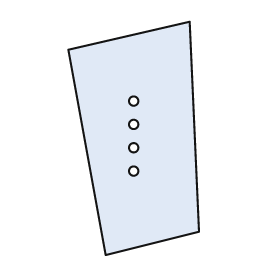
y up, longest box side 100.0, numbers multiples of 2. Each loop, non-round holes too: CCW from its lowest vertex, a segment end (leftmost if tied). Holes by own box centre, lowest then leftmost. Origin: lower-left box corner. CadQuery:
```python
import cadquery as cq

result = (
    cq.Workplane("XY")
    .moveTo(16.0, 0.0)
    .lineTo(56.0, 10.0)
    .lineTo(52.0, 100.0)
    .lineTo(0.0, 88.0)
    .close()
    .moveTo(28.0, 36.0)
    .circle(2.0)
    .moveTo(28.0, 46.0)
    .circle(2.0)
    .moveTo(28.0, 56.0)
    .circle(2.0)
    .moveTo(28.0, 66.0)
    .circle(2.0)
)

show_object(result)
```